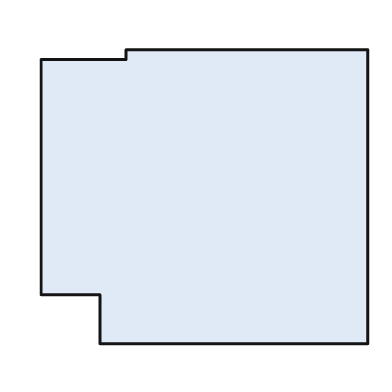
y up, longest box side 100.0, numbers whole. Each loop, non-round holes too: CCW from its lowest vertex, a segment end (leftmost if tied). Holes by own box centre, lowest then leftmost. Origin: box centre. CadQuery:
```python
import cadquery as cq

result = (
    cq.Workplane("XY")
    .moveTo(-32.0, -45.0)
    .lineTo(50.0, -45.0)
    .lineTo(50.0, 45.0)
    .lineTo(-24.0, 45.0)
    .lineTo(-24.0, 42.0)
    .lineTo(-50.0, 42.0)
    .lineTo(-50.0, -30.0)
    .lineTo(-32.0, -30.0)
    .close()
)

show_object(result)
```